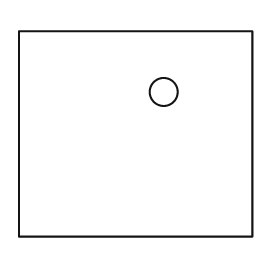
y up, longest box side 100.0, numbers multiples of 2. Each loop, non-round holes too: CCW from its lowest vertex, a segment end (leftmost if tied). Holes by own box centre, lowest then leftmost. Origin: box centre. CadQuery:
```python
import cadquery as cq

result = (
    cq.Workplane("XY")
    .moveTo(-50.0, -44.0)
    .lineTo(50.0, -44.0)
    .lineTo(50.0, 44.0)
    .lineTo(-50.0, 44.0)
    .close()
    .moveTo(12.0, 18.0)
    .circle(6.0)
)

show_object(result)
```